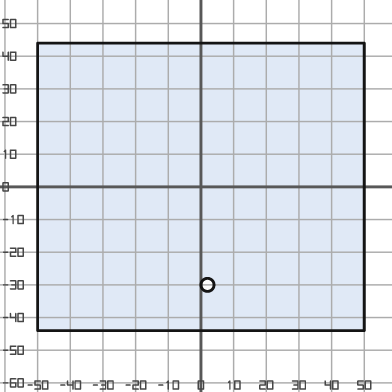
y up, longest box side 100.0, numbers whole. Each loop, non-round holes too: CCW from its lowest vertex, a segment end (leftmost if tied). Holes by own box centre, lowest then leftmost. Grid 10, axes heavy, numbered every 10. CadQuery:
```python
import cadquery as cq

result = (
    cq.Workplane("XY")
    .moveTo(-50.0, -44.0)
    .lineTo(50.0, -44.0)
    .lineTo(50.0, 44.0)
    .lineTo(-50.0, 44.0)
    .close()
    .moveTo(2.0, -30.0)
    .circle(2.0)
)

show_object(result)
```